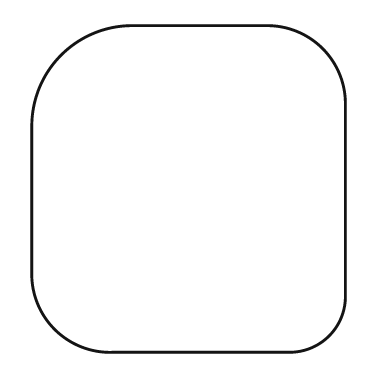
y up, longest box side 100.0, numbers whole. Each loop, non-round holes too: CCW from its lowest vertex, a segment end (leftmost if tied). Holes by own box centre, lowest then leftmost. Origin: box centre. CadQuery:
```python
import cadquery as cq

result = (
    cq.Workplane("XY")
    .moveTo(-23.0, -50.0)
    .lineTo(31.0, -50.0)
    .threePointArc((43.0, -45.0), (48.0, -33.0))
    .lineTo(48.0, 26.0)
    .threePointArc((41.0, 43.0), (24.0, 50.0))
    .lineTo(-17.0, 50.0)
    .threePointArc((-39.0, 41.0), (-48.0, 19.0))
    .lineTo(-48.0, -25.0)
    .threePointArc((-41.0, -43.0), (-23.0, -50.0))
    .close()
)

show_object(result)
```